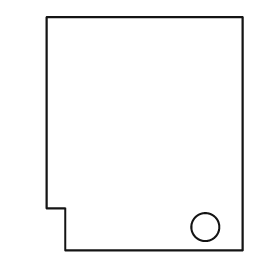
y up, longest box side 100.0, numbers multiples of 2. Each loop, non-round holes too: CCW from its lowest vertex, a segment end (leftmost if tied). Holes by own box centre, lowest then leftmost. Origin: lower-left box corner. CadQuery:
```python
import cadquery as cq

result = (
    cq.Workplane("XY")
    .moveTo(8.0, 0.0)
    .lineTo(84.0, 0.0)
    .lineTo(84.0, 100.0)
    .lineTo(0.0, 100.0)
    .lineTo(0.0, 18.0)
    .lineTo(8.0, 18.0)
    .close()
    .moveTo(68.0, 10.0)
    .circle(6.0)
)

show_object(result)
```